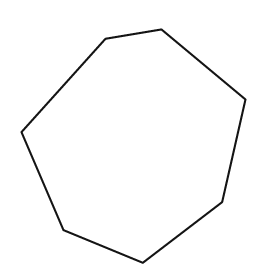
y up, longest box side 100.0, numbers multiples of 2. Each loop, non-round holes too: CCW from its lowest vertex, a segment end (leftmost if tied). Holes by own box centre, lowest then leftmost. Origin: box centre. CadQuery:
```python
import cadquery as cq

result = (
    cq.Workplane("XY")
    .moveTo(4.0, -50.0)
    .lineTo(38.0, -24.0)
    .lineTo(48.0, 20.0)
    .lineTo(12.0, 50.0)
    .lineTo(-12.0, 46.0)
    .lineTo(-48.0, 6.0)
    .lineTo(-30.0, -36.0)
    .close()
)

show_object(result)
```